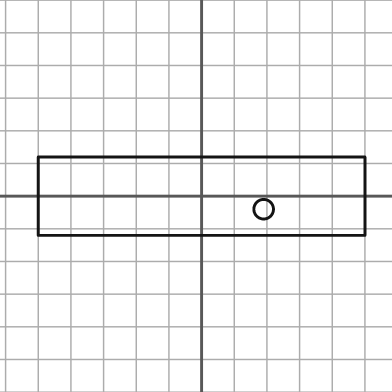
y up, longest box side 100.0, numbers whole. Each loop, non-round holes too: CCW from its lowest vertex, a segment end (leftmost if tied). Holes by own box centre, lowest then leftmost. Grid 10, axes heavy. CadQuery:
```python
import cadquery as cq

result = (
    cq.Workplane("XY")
    .moveTo(-50.0, -12.0)
    .lineTo(50.0, -12.0)
    .lineTo(50.0, 12.0)
    .lineTo(-50.0, 12.0)
    .close()
    .moveTo(19.0, -4.0)
    .circle(3.0)
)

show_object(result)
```